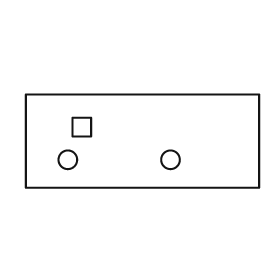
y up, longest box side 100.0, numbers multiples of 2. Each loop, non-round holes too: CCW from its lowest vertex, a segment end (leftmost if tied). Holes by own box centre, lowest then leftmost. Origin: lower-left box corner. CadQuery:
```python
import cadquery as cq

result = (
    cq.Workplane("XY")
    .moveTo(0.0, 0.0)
    .lineTo(100.0, 0.0)
    .lineTo(100.0, 40.0)
    .lineTo(0.0, 40.0)
    .close()
    .moveTo(18.0, 12.0)
    .circle(4.0)
    .moveTo(62.0, 12.0)
    .circle(4.0)
    .moveTo(20.0, 22.0)
    .lineTo(28.0, 22.0)
    .lineTo(28.0, 30.0)
    .lineTo(20.0, 30.0)
    .close()
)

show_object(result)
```